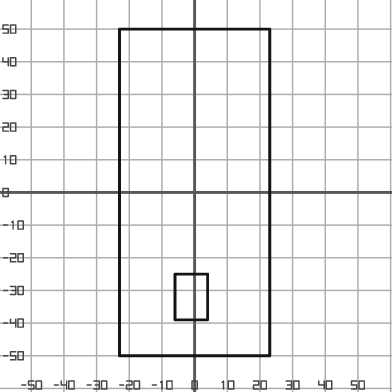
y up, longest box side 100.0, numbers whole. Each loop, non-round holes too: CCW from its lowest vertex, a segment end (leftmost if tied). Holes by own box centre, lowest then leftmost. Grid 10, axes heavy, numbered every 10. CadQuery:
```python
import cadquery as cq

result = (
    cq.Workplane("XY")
    .moveTo(-23.0, -50.0)
    .lineTo(23.0, -50.0)
    .lineTo(23.0, 50.0)
    .lineTo(-23.0, 50.0)
    .close()
    .moveTo(-6.0, -39.0)
    .lineTo(4.0, -39.0)
    .lineTo(4.0, -25.0)
    .lineTo(-6.0, -25.0)
    .close()
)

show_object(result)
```